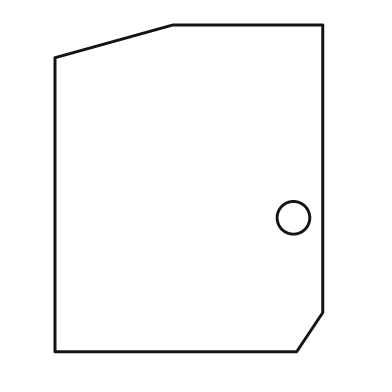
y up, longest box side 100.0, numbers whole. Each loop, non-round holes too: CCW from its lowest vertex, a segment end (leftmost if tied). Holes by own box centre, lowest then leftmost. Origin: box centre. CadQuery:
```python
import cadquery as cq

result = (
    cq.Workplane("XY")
    .moveTo(-41.0, -50.0)
    .lineTo(33.0, -50.0)
    .lineTo(41.0, -38.0)
    .lineTo(41.0, 50.0)
    .lineTo(-5.0, 50.0)
    .lineTo(-41.0, 40.0)
    .close()
    .moveTo(32.0, -9.0)
    .circle(5.0)
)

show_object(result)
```